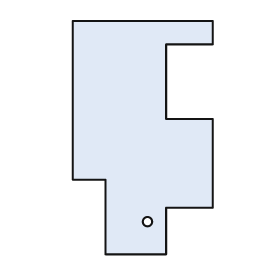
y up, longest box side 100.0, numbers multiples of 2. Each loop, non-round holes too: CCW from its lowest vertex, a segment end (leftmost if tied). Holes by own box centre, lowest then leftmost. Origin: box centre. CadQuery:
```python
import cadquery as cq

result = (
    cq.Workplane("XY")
    .moveTo(-16.0, -50.0)
    .lineTo(10.0, -50.0)
    .lineTo(10.0, -30.0)
    .lineTo(30.0, -30.0)
    .lineTo(30.0, 8.0)
    .lineTo(10.0, 8.0)
    .lineTo(10.0, 40.0)
    .lineTo(30.0, 40.0)
    .lineTo(30.0, 50.0)
    .lineTo(-30.0, 50.0)
    .lineTo(-30.0, -18.0)
    .lineTo(-16.0, -18.0)
    .close()
    .moveTo(2.0, -36.0)
    .circle(2.0)
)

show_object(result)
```